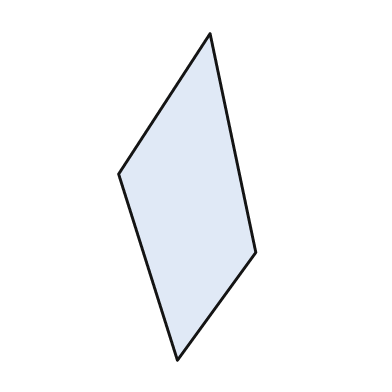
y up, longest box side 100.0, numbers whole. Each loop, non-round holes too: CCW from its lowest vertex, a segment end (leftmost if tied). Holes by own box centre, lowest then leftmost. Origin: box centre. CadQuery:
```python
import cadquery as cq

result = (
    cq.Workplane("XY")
    .moveTo(-3.0, -50.0)
    .lineTo(21.0, -17.0)
    .lineTo(7.0, 50.0)
    .lineTo(-21.0, 7.0)
    .close()
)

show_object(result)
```